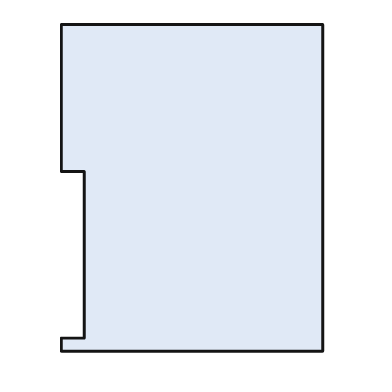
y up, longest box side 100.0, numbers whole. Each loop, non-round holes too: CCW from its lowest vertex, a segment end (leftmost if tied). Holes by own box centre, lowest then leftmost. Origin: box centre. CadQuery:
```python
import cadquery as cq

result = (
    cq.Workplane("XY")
    .moveTo(-40.0, -50.0)
    .lineTo(40.0, -50.0)
    .lineTo(40.0, 50.0)
    .lineTo(-40.0, 50.0)
    .lineTo(-40.0, 5.0)
    .lineTo(-33.0, 5.0)
    .lineTo(-33.0, -46.0)
    .lineTo(-40.0, -46.0)
    .close()
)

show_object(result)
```